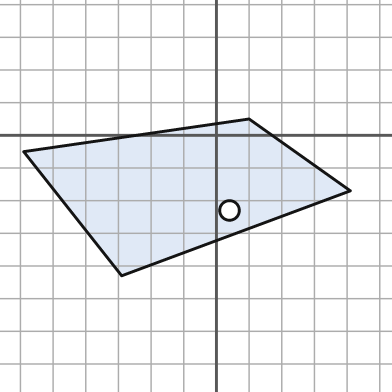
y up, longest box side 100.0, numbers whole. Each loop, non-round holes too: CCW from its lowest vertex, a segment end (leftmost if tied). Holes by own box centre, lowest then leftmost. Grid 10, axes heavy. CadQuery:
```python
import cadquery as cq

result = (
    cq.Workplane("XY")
    .moveTo(-29.0, -43.0)
    .lineTo(41.0, -17.0)
    .lineTo(10.0, 5.0)
    .lineTo(-59.0, -5.0)
    .close()
    .moveTo(4.0, -23.0)
    .circle(3.0)
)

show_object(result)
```